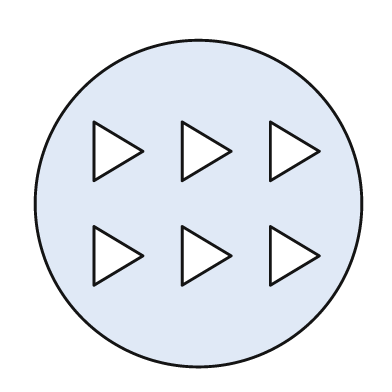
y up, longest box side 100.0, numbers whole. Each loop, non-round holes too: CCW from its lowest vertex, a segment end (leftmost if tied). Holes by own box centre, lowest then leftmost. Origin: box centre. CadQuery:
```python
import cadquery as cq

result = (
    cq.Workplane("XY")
    .moveTo(0.0, 0.0)
    .circle(50.0)
    .moveTo(-32.0, -25.0)
    .lineTo(-17.0, -16.0)
    .lineTo(-32.0, -7.0)
    .close()
    .moveTo(-5.0, -25.0)
    .lineTo(10.0, -16.0)
    .lineTo(-5.0, -7.0)
    .close()
    .moveTo(22.0, -25.0)
    .lineTo(37.0, -16.0)
    .lineTo(22.0, -7.0)
    .close()
    .moveTo(-32.0, 7.0)
    .lineTo(-17.0, 16.0)
    .lineTo(-32.0, 25.0)
    .close()
    .moveTo(-5.0, 7.0)
    .lineTo(10.0, 16.0)
    .lineTo(-5.0, 25.0)
    .close()
    .moveTo(22.0, 7.0)
    .lineTo(37.0, 16.0)
    .lineTo(22.0, 25.0)
    .close()
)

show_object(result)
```